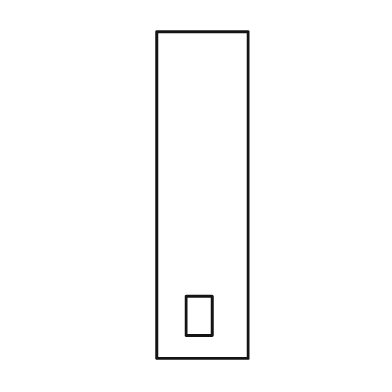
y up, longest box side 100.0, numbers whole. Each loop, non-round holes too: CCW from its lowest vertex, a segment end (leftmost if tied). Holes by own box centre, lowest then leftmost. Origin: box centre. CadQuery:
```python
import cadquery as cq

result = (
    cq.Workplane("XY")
    .moveTo(-14.0, -50.0)
    .lineTo(14.0, -50.0)
    .lineTo(14.0, 50.0)
    .lineTo(-14.0, 50.0)
    .close()
    .moveTo(-5.0, -43.0)
    .lineTo(3.0, -43.0)
    .lineTo(3.0, -31.0)
    .lineTo(-5.0, -31.0)
    .close()
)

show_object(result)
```